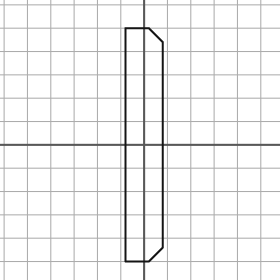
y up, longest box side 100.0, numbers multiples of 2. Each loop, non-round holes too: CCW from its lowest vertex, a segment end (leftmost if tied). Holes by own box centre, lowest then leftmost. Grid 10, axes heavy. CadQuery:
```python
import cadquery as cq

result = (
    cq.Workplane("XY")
    .moveTo(-8.0, -50.0)
    .lineTo(2.0, -50.0)
    .lineTo(8.0, -44.0)
    .lineTo(8.0, 44.0)
    .lineTo(2.0, 50.0)
    .lineTo(-8.0, 50.0)
    .close()
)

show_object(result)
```